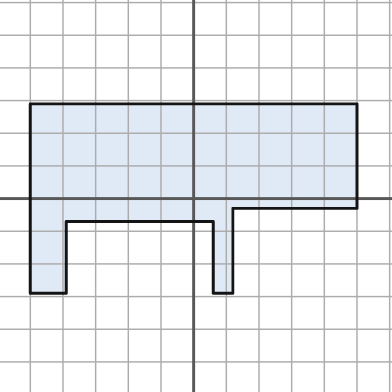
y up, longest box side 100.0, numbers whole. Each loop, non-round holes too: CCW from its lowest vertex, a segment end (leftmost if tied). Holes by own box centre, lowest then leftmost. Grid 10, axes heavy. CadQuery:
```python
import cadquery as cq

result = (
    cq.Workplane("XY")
    .moveTo(-50.0, -29.0)
    .lineTo(-39.0, -29.0)
    .lineTo(-39.0, -7.0)
    .lineTo(6.0, -7.0)
    .lineTo(6.0, -29.0)
    .lineTo(12.0, -29.0)
    .lineTo(12.0, -3.0)
    .lineTo(50.0, -3.0)
    .lineTo(50.0, 29.0)
    .lineTo(-50.0, 29.0)
    .close()
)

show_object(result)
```